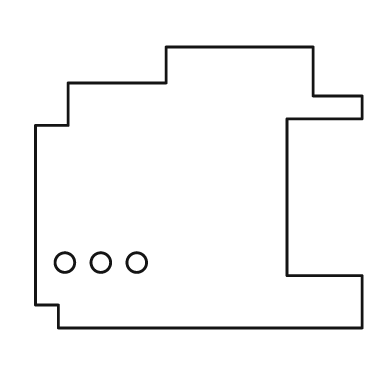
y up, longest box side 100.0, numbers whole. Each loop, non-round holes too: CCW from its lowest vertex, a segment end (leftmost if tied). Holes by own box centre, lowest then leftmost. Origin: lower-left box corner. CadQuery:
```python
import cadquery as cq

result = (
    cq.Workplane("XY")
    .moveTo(7.0, 0.0)
    .lineTo(100.0, 0.0)
    .lineTo(100.0, 16.0)
    .lineTo(77.0, 16.0)
    .lineTo(77.0, 64.0)
    .lineTo(100.0, 64.0)
    .lineTo(100.0, 71.0)
    .lineTo(85.0, 71.0)
    .lineTo(85.0, 86.0)
    .lineTo(40.0, 86.0)
    .lineTo(40.0, 75.0)
    .lineTo(10.0, 75.0)
    .lineTo(10.0, 62.0)
    .lineTo(0.0, 62.0)
    .lineTo(0.0, 7.0)
    .lineTo(7.0, 7.0)
    .close()
    .moveTo(9.0, 20.0)
    .circle(3.0)
    .moveTo(20.0, 20.0)
    .circle(3.0)
    .moveTo(31.0, 20.0)
    .circle(3.0)
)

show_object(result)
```